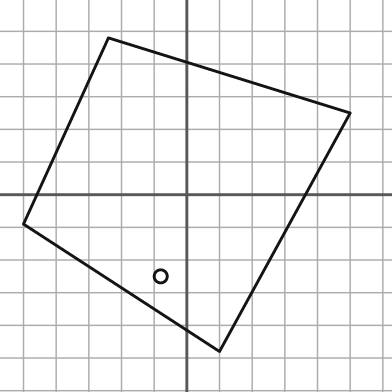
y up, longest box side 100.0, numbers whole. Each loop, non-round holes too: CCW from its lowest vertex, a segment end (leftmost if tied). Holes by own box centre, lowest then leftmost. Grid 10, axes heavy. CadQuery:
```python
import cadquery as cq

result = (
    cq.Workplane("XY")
    .moveTo(10.0, -48.0)
    .lineTo(50.0, 25.0)
    .lineTo(-24.0, 48.0)
    .lineTo(-50.0, -9.0)
    .close()
    .moveTo(-8.0, -25.0)
    .circle(2.0)
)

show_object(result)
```